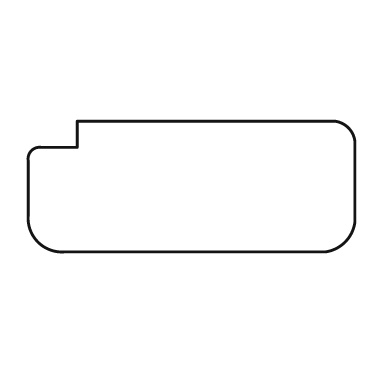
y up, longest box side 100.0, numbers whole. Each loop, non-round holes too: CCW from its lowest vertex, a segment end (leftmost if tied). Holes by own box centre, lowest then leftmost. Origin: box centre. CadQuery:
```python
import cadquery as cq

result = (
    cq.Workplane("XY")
    .moveTo(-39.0, -20.0)
    .lineTo(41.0, -20.0)
    .threePointArc((47.0, -17.0), (50.0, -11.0))
    .lineTo(50.0, 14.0)
    .threePointArc((48.0, 18.0), (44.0, 20.0))
    .lineTo(-35.0, 20.0)
    .lineTo(-35.0, 12.0)
    .lineTo(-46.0, 12.0)
    .threePointArc((-49.0, 11.0), (-50.0, 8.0))
    .lineTo(-50.0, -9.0)
    .threePointArc((-47.0, -17.0), (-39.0, -20.0))
    .close()
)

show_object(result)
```